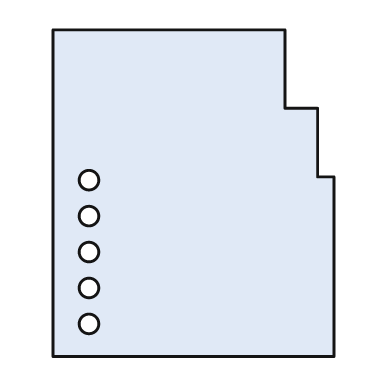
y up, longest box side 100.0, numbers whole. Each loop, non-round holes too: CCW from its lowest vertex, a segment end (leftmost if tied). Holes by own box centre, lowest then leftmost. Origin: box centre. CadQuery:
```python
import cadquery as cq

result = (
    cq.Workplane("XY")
    .moveTo(-43.0, -50.0)
    .lineTo(43.0, -50.0)
    .lineTo(43.0, 5.0)
    .lineTo(38.0, 5.0)
    .lineTo(38.0, 26.0)
    .lineTo(28.0, 26.0)
    .lineTo(28.0, 50.0)
    .lineTo(-43.0, 50.0)
    .close()
    .moveTo(-32.0, -40.0)
    .circle(3.0)
    .moveTo(-32.0, -29.0)
    .circle(3.0)
    .moveTo(-32.0, -18.0)
    .circle(3.0)
    .moveTo(-32.0, -7.0)
    .circle(3.0)
    .moveTo(-32.0, 4.0)
    .circle(3.0)
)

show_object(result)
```